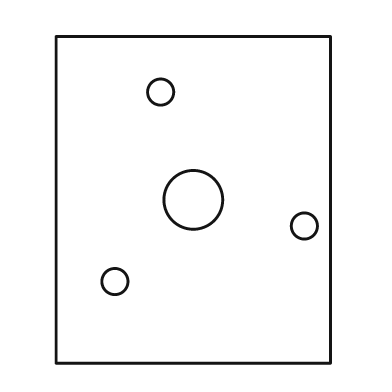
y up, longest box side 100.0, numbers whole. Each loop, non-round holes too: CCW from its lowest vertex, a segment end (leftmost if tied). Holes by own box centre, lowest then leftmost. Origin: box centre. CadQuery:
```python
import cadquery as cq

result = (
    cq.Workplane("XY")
    .moveTo(-42.0, -50.0)
    .lineTo(42.0, -50.0)
    .lineTo(42.0, 50.0)
    .lineTo(-42.0, 50.0)
    .close()
    .moveTo(-24.0, -25.0)
    .circle(4.0)
    .moveTo(34.0, -8.0)
    .circle(4.0)
    .moveTo(0.0, 0.0)
    .circle(9.0)
    .moveTo(-10.0, 33.0)
    .circle(4.0)
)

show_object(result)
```